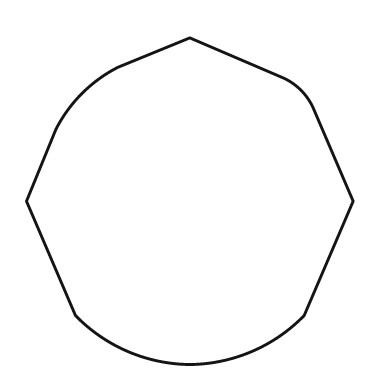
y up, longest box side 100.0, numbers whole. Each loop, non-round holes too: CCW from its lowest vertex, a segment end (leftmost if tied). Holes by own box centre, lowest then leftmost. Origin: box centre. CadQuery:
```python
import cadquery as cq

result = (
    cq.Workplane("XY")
    .moveTo(0.0, -50.0)
    .threePointArc((19.0, -46.0), (35.0, -35.0))
    .lineTo(50.0, 0.0)
    .lineTo(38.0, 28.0)
    .threePointArc((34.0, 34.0), (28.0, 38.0))
    .lineTo(0.0, 50.0)
    .lineTo(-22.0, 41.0)
    .threePointArc((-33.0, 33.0), (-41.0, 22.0))
    .lineTo(-50.0, 0.0)
    .lineTo(-35.0, -35.0)
    .threePointArc((-19.0, -46.0), (0.0, -50.0))
    .close()
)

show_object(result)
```